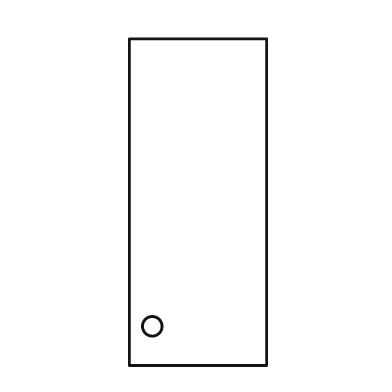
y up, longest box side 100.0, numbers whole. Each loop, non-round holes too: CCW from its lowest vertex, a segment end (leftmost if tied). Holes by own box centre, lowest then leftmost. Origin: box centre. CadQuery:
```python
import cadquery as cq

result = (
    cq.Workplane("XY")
    .moveTo(-21.0, -50.0)
    .lineTo(21.0, -50.0)
    .lineTo(21.0, 50.0)
    .lineTo(-21.0, 50.0)
    .close()
    .moveTo(-14.0, -38.0)
    .circle(3.0)
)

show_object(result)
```